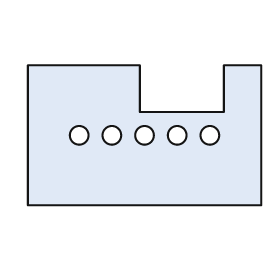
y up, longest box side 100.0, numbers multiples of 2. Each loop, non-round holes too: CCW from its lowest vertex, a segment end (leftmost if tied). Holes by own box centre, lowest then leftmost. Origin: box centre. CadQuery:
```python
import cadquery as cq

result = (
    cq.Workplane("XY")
    .moveTo(-50.0, -30.0)
    .lineTo(50.0, -30.0)
    .lineTo(50.0, 30.0)
    .lineTo(34.0, 30.0)
    .lineTo(34.0, 10.0)
    .lineTo(-2.0, 10.0)
    .lineTo(-2.0, 30.0)
    .lineTo(-50.0, 30.0)
    .close()
    .moveTo(-28.0, 0.0)
    .circle(4.0)
    .moveTo(-14.0, 0.0)
    .circle(4.0)
    .moveTo(0.0, 0.0)
    .circle(4.0)
    .moveTo(14.0, 0.0)
    .circle(4.0)
    .moveTo(28.0, 0.0)
    .circle(4.0)
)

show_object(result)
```